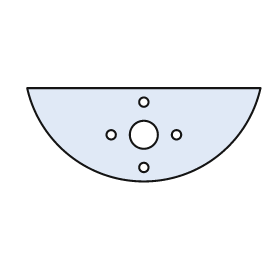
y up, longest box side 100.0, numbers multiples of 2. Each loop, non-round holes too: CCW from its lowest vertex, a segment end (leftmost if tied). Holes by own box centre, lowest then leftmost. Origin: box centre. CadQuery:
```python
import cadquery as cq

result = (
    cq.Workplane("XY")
    .moveTo(-50.0, 20.0)
    .threePointArc((0.0, -20.0), (50.0, 20.0))
    .close()
    .moveTo(0.0, -14.0)
    .circle(2.0)
    .moveTo(-14.0, 0.0)
    .circle(2.0)
    .moveTo(0.0, 0.0)
    .circle(6.0)
    .moveTo(14.0, 0.0)
    .circle(2.0)
    .moveTo(0.0, 14.0)
    .circle(2.0)
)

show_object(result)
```